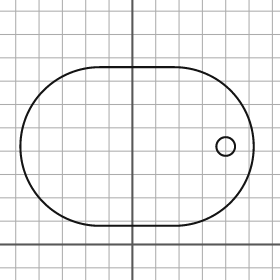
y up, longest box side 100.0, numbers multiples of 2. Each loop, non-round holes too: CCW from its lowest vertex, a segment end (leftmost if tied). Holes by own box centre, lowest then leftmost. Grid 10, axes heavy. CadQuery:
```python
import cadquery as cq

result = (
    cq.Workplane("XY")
    .moveTo(-14.0, 8.0)
    .lineTo(18.0, 8.0)
    .threePointArc((52.0, 42.0), (18.0, 76.0))
    .lineTo(-14.0, 76.0)
    .threePointArc((-48.0, 42.0), (-14.0, 8.0))
    .close()
    .moveTo(40.0, 42.0)
    .circle(4.0)
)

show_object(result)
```